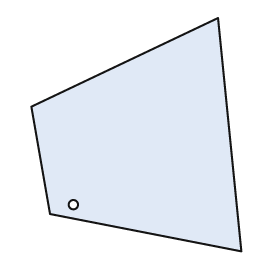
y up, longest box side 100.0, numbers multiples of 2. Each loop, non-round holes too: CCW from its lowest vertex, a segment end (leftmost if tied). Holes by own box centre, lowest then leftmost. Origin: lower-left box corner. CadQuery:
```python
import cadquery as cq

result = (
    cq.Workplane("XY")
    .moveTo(90.0, 0.0)
    .lineTo(80.0, 100.0)
    .lineTo(0.0, 62.0)
    .lineTo(8.0, 16.0)
    .close()
    .moveTo(18.0, 20.0)
    .circle(2.0)
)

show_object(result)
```